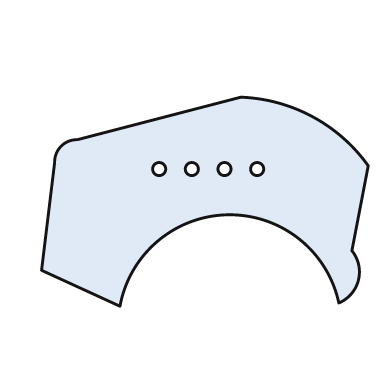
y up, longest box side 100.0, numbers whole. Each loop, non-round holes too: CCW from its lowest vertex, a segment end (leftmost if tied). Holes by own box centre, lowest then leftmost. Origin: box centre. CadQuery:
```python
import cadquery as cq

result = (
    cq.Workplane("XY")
    .moveTo(-26.0, -32.0)
    .threePointArc((7.0, -4.0), (41.0, -31.0))
    .threePointArc((47.0, -24.0), (45.0, -15.0))
    .lineTo(50.0, 11.0)
    .threePointArc((33.0, 26.0), (11.0, 32.0))
    .lineTo(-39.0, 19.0)
    .threePointArc((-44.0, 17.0), (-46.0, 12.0))
    .lineTo(-50.0, -21.0)
    .close()
    .moveTo(-14.0, 10.0)
    .circle(2.0)
    .moveTo(-4.0, 10.0)
    .circle(2.0)
    .moveTo(6.0, 10.0)
    .circle(2.0)
    .moveTo(16.0, 10.0)
    .circle(2.0)
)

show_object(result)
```